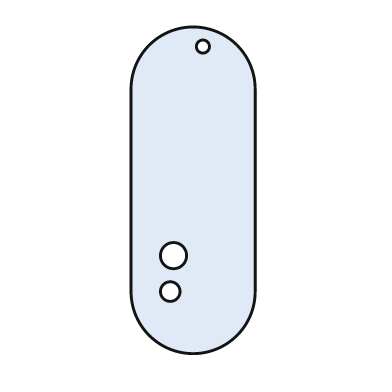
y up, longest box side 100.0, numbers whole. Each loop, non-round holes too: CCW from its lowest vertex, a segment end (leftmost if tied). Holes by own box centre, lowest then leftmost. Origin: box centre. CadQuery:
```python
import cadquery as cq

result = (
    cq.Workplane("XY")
    .moveTo(-19.0, -31.0)
    .threePointArc((0.0, -50.0), (19.0, -31.0))
    .lineTo(19.0, 31.0)
    .threePointArc((0.0, 50.0), (-19.0, 31.0))
    .close()
    .moveTo(-7.0, -31.0)
    .circle(3.0)
    .moveTo(-6.0, -20.0)
    .circle(4.0)
    .moveTo(3.0, 44.0)
    .circle(2.0)
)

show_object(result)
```